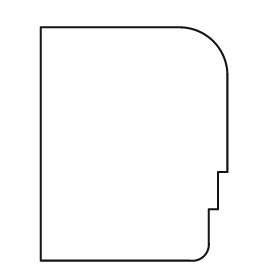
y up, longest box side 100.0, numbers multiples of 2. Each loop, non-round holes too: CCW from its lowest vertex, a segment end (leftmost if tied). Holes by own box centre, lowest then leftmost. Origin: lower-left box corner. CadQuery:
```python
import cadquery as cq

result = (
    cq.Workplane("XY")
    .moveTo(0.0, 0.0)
    .lineTo(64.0, 0.0)
    .threePointArc((70.0, 2.0), (72.0, 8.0))
    .lineTo(72.0, 22.0)
    .lineTo(76.0, 22.0)
    .lineTo(76.0, 38.0)
    .lineTo(80.0, 38.0)
    .lineTo(80.0, 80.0)
    .threePointArc((74.0, 94.0), (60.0, 100.0))
    .lineTo(0.0, 100.0)
    .close()
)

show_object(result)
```